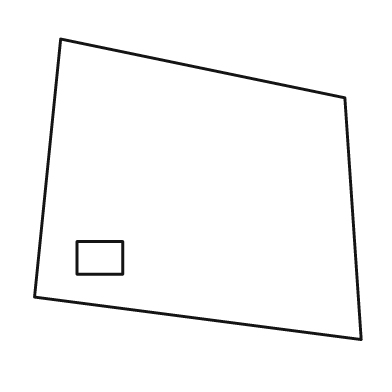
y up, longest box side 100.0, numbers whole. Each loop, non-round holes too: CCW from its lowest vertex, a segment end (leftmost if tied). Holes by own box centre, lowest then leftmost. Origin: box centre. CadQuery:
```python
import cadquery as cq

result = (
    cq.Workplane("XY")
    .moveTo(50.0, -46.0)
    .lineTo(45.0, 28.0)
    .lineTo(-42.0, 46.0)
    .lineTo(-50.0, -33.0)
    .close()
    .moveTo(-37.0, -26.0)
    .lineTo(-23.0, -26.0)
    .lineTo(-23.0, -16.0)
    .lineTo(-37.0, -16.0)
    .close()
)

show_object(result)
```